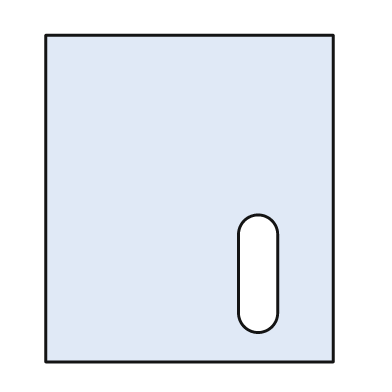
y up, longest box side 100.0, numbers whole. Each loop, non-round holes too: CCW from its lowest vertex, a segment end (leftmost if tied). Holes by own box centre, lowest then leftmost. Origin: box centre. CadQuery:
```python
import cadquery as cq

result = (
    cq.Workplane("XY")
    .moveTo(-44.0, -50.0)
    .lineTo(44.0, -50.0)
    .lineTo(44.0, 50.0)
    .lineTo(-44.0, 50.0)
    .close()
    .moveTo(15.0, -35.0)
    .threePointArc((21.0, -41.0), (27.0, -35.0))
    .lineTo(27.0, -11.0)
    .threePointArc((21.0, -5.0), (15.0, -11.0))
    .close()
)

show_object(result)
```